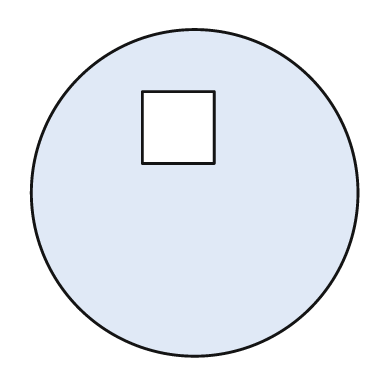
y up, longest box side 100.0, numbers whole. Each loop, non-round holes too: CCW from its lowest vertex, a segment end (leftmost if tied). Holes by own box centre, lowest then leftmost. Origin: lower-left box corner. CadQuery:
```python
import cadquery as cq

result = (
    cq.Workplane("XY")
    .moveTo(50.0, 50.0)
    .circle(50.0)
    .moveTo(34.0, 59.0)
    .lineTo(56.0, 59.0)
    .lineTo(56.0, 81.0)
    .lineTo(34.0, 81.0)
    .close()
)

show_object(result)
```